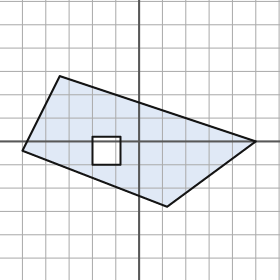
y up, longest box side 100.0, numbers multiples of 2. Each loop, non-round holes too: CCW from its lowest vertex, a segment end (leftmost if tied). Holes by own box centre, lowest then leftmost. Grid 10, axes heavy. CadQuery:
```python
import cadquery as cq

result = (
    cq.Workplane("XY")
    .moveTo(12.0, -28.0)
    .lineTo(50.0, 0.0)
    .lineTo(-34.0, 28.0)
    .lineTo(-50.0, -4.0)
    .close()
    .moveTo(-20.0, -10.0)
    .lineTo(-8.0, -10.0)
    .lineTo(-8.0, 2.0)
    .lineTo(-20.0, 2.0)
    .close()
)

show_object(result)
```